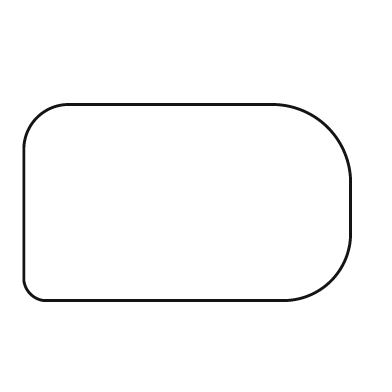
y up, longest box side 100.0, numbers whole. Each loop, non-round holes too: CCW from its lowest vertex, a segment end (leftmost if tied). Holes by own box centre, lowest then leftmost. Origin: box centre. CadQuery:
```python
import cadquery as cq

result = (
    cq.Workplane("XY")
    .moveTo(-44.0, -30.0)
    .lineTo(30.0, -30.0)
    .threePointArc((44.0, -24.0), (50.0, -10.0))
    .lineTo(50.0, 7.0)
    .threePointArc((43.0, 23.0), (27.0, 30.0))
    .lineTo(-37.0, 30.0)
    .threePointArc((-46.0, 26.0), (-50.0, 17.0))
    .lineTo(-50.0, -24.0)
    .threePointArc((-48.0, -28.0), (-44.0, -30.0))
    .close()
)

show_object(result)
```